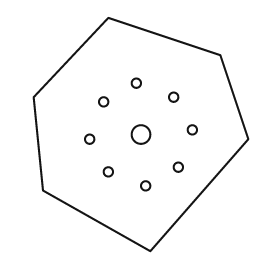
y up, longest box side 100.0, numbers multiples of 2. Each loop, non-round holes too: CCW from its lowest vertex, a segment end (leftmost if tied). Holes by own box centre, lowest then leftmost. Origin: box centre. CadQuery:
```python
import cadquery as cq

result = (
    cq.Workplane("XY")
    .moveTo(4.0, -50.0)
    .lineTo(46.0, -2.0)
    .lineTo(34.0, 34.0)
    .lineTo(-14.0, 50.0)
    .lineTo(-46.0, 16.0)
    .lineTo(-42.0, -24.0)
    .close()
    .moveTo(2.0, -22.0)
    .circle(2.0)
    .moveTo(-14.0, -16.0)
    .circle(2.0)
    .moveTo(16.0, -14.0)
    .circle(2.0)
    .moveTo(-22.0, -2.0)
    .circle(2.0)
    .moveTo(0.0, 0.0)
    .circle(4.0)
    .moveTo(22.0, 2.0)
    .circle(2.0)
    .moveTo(-16.0, 14.0)
    .circle(2.0)
    .moveTo(14.0, 16.0)
    .circle(2.0)
    .moveTo(-2.0, 22.0)
    .circle(2.0)
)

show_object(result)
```